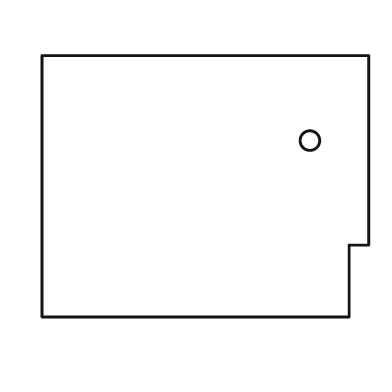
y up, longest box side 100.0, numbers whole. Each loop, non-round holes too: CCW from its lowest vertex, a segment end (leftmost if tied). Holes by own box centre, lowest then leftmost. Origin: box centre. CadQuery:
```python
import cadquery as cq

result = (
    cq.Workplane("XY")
    .moveTo(-50.0, -40.0)
    .lineTo(44.0, -40.0)
    .lineTo(44.0, -18.0)
    .lineTo(50.0, -18.0)
    .lineTo(50.0, 40.0)
    .lineTo(-50.0, 40.0)
    .close()
    .moveTo(32.0, 14.0)
    .circle(3.0)
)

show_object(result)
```